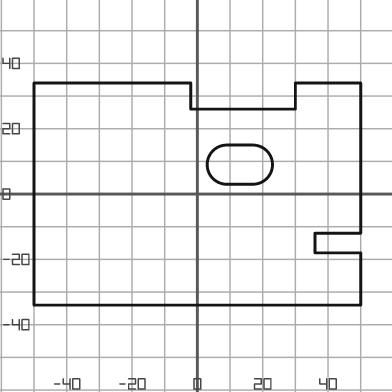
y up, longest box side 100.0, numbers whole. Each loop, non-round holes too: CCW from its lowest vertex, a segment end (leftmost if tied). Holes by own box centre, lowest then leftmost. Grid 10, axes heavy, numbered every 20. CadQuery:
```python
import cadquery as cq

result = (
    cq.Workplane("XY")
    .moveTo(-50.0, -34.0)
    .lineTo(50.0, -34.0)
    .lineTo(50.0, -18.0)
    .lineTo(36.0, -18.0)
    .lineTo(36.0, -12.0)
    .lineTo(50.0, -12.0)
    .lineTo(50.0, 34.0)
    .lineTo(30.0, 34.0)
    .lineTo(30.0, 26.0)
    .lineTo(-2.0, 26.0)
    .lineTo(-2.0, 34.0)
    .lineTo(-50.0, 34.0)
    .close()
    .moveTo(9.0, 3.0)
    .lineTo(17.0, 3.0)
    .threePointArc((23.0, 9.0), (17.0, 15.0))
    .lineTo(9.0, 15.0)
    .threePointArc((3.0, 9.0), (9.0, 3.0))
    .close()
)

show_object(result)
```